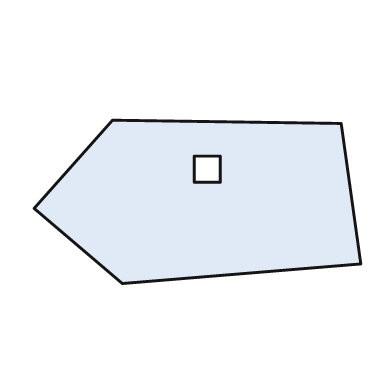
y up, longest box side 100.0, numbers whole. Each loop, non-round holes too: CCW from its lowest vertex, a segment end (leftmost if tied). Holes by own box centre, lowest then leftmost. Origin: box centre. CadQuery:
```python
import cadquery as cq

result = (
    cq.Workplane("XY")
    .moveTo(-23.0, -25.0)
    .lineTo(50.0, -19.0)
    .lineTo(44.0, 24.0)
    .lineTo(-26.0, 25.0)
    .lineTo(-50.0, -2.0)
    .close()
    .moveTo(-1.0, 6.0)
    .lineTo(7.0, 6.0)
    .lineTo(7.0, 14.0)
    .lineTo(-1.0, 14.0)
    .close()
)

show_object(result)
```